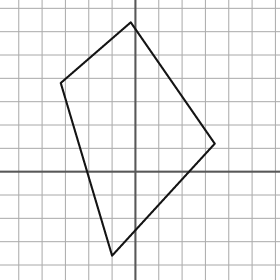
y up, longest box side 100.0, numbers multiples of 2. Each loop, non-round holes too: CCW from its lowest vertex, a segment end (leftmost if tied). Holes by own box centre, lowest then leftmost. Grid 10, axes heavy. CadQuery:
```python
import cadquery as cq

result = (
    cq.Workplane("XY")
    .moveTo(-10.0, -36.0)
    .lineTo(34.0, 12.0)
    .lineTo(-2.0, 64.0)
    .lineTo(-32.0, 38.0)
    .close()
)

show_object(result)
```